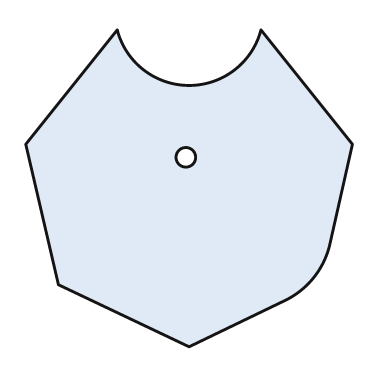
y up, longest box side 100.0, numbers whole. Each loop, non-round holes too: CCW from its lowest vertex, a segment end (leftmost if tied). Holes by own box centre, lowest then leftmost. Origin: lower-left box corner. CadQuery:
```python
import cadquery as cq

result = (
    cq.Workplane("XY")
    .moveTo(50.0, 0.0)
    .lineTo(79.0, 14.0)
    .threePointArc((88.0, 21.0), (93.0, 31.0))
    .lineTo(100.0, 62.0)
    .lineTo(72.0, 97.0)
    .threePointArc((50.0, 80.0), (28.0, 97.0))
    .lineTo(0.0, 62.0)
    .lineTo(10.0, 19.0)
    .close()
    .moveTo(49.0, 58.0)
    .circle(3.0)
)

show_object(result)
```